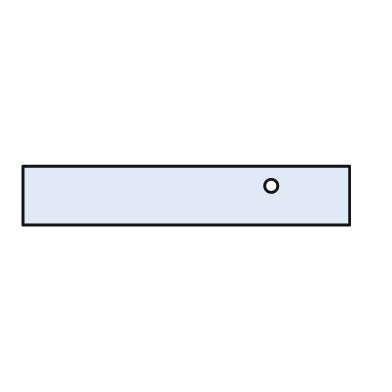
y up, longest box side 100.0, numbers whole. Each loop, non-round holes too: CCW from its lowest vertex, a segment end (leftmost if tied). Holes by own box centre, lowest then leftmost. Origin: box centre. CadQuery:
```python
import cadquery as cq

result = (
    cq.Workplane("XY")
    .moveTo(-50.0, -9.0)
    .lineTo(50.0, -9.0)
    .lineTo(50.0, 9.0)
    .lineTo(-50.0, 9.0)
    .close()
    .moveTo(26.0, 3.0)
    .circle(2.0)
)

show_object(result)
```